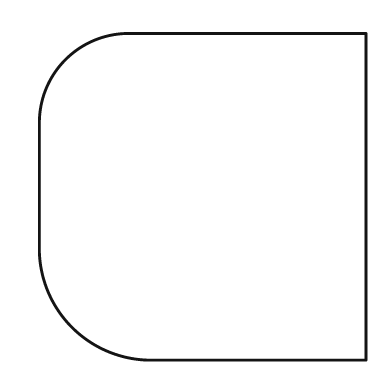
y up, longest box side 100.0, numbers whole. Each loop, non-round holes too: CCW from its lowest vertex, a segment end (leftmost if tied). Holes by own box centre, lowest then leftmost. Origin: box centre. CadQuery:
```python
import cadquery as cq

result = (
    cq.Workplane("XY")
    .moveTo(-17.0, -50.0)
    .lineTo(50.0, -50.0)
    .lineTo(50.0, 50.0)
    .lineTo(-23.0, 50.0)
    .threePointArc((-42.0, 42.0), (-50.0, 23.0))
    .lineTo(-50.0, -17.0)
    .threePointArc((-40.0, -40.0), (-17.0, -50.0))
    .close()
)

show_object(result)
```